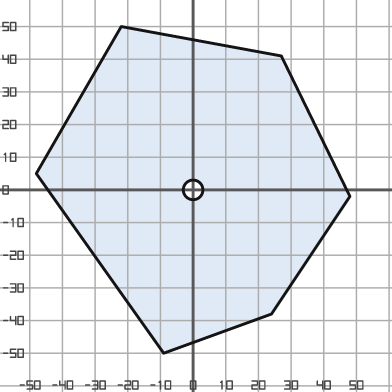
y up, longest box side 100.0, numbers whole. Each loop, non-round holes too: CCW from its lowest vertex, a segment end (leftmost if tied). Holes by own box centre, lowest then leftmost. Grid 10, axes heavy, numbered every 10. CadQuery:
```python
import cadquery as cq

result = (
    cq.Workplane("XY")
    .moveTo(-9.0, -50.0)
    .lineTo(24.0, -38.0)
    .lineTo(48.0, -2.0)
    .lineTo(27.0, 41.0)
    .lineTo(-22.0, 50.0)
    .lineTo(-48.0, 5.0)
    .close()
    .moveTo(0.0, 0.0)
    .circle(3.0)
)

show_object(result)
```